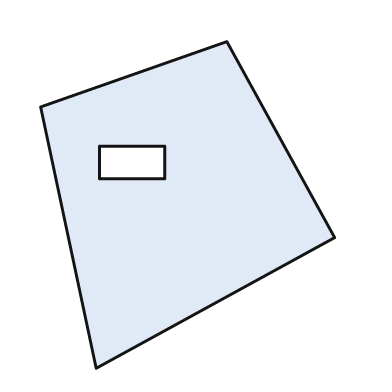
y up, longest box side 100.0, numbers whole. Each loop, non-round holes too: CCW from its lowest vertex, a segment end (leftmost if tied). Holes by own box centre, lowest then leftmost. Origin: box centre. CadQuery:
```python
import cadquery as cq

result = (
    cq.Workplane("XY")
    .moveTo(-28.0, -50.0)
    .lineTo(45.0, -10.0)
    .lineTo(12.0, 50.0)
    .lineTo(-45.0, 30.0)
    .close()
    .moveTo(-27.0, 8.0)
    .lineTo(-7.0, 8.0)
    .lineTo(-7.0, 18.0)
    .lineTo(-27.0, 18.0)
    .close()
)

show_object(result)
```